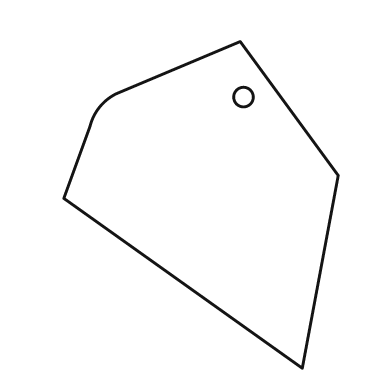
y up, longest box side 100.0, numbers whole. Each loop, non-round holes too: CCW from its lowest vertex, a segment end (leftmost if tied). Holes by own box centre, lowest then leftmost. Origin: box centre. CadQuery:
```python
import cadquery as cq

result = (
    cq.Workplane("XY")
    .moveTo(31.0, -50.0)
    .lineTo(42.0, 9.0)
    .lineTo(12.0, 50.0)
    .lineTo(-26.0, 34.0)
    .threePointArc((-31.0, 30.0), (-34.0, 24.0))
    .lineTo(-42.0, 2.0)
    .close()
    .moveTo(13.0, 33.0)
    .circle(3.0)
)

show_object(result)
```